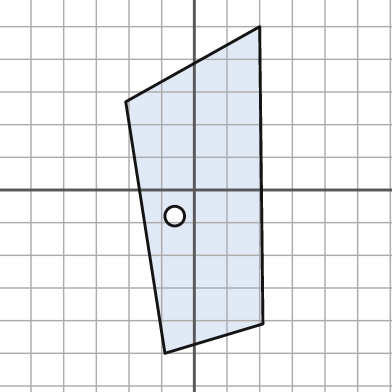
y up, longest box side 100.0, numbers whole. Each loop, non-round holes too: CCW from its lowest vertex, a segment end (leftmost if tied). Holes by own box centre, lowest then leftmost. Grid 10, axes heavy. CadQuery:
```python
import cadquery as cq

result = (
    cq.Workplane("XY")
    .moveTo(-9.0, -50.0)
    .lineTo(21.0, -41.0)
    .lineTo(20.0, 50.0)
    .lineTo(-21.0, 27.0)
    .close()
    .moveTo(-6.0, -8.0)
    .circle(3.0)
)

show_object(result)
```